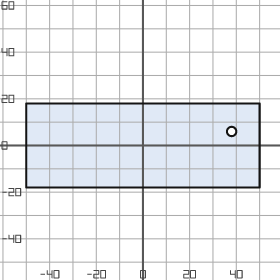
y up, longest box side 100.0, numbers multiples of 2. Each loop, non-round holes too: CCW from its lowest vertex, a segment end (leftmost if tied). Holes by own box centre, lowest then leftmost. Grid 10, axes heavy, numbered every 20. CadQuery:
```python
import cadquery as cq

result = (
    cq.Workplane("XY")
    .moveTo(-50.0, -18.0)
    .lineTo(50.0, -18.0)
    .lineTo(50.0, 18.0)
    .lineTo(-50.0, 18.0)
    .close()
    .moveTo(38.0, 6.0)
    .circle(2.0)
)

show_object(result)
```